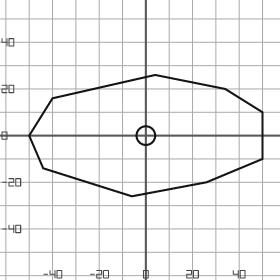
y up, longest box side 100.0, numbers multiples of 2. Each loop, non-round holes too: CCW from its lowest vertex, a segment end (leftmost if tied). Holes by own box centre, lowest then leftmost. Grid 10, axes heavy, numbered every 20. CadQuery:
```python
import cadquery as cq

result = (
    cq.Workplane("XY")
    .moveTo(-6.0, -26.0)
    .lineTo(26.0, -20.0)
    .lineTo(50.0, -10.0)
    .lineTo(50.0, 10.0)
    .lineTo(34.0, 20.0)
    .lineTo(4.0, 26.0)
    .lineTo(-40.0, 16.0)
    .lineTo(-50.0, 0.0)
    .lineTo(-44.0, -14.0)
    .close()
    .moveTo(0.0, 0.0)
    .circle(4.0)
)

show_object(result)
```